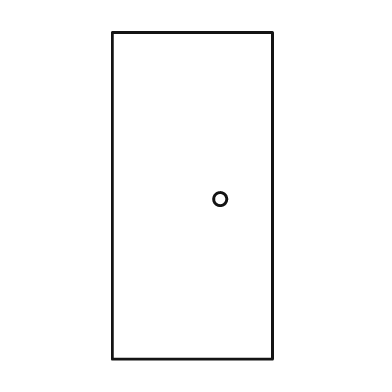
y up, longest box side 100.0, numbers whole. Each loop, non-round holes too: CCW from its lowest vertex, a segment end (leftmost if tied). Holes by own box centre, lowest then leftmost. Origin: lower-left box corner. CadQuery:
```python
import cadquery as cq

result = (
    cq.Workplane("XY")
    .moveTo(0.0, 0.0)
    .lineTo(49.0, 0.0)
    .lineTo(49.0, 100.0)
    .lineTo(0.0, 100.0)
    .close()
    .moveTo(33.0, 49.0)
    .circle(2.0)
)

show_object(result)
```